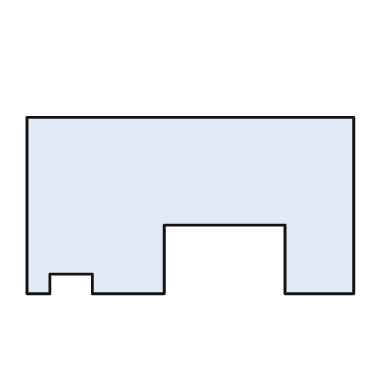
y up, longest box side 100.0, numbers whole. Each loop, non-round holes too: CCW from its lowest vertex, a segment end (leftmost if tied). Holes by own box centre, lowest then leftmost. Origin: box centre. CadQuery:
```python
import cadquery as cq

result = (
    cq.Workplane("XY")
    .moveTo(-50.0, -27.0)
    .lineTo(-43.0, -27.0)
    .lineTo(-43.0, -21.0)
    .lineTo(-30.0, -21.0)
    .lineTo(-30.0, -27.0)
    .lineTo(-8.0, -27.0)
    .lineTo(-8.0, -6.0)
    .lineTo(29.0, -6.0)
    .lineTo(29.0, -27.0)
    .lineTo(50.0, -27.0)
    .lineTo(50.0, 27.0)
    .lineTo(-50.0, 27.0)
    .close()
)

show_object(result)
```